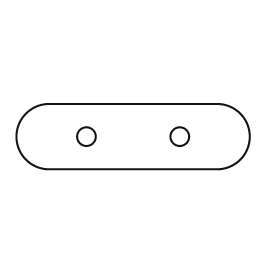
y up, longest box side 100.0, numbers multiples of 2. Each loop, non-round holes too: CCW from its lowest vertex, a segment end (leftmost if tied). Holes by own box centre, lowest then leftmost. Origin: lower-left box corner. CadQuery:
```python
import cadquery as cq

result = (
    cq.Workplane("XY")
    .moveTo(14.0, 0.0)
    .lineTo(86.0, 0.0)
    .threePointArc((100.0, 14.0), (86.0, 28.0))
    .lineTo(14.0, 28.0)
    .threePointArc((0.0, 14.0), (14.0, 0.0))
    .close()
    .moveTo(30.0, 14.0)
    .circle(4.0)
    .moveTo(70.0, 14.0)
    .circle(4.0)
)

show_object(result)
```